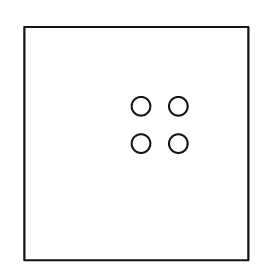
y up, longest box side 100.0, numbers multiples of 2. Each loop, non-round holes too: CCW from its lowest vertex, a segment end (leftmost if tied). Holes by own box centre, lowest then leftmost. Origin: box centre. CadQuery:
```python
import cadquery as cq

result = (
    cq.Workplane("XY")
    .moveTo(-48.0, -50.0)
    .lineTo(48.0, -50.0)
    .lineTo(48.0, 50.0)
    .lineTo(-48.0, 50.0)
    .close()
    .moveTo(2.0, 0.0)
    .circle(4.0)
    .moveTo(18.0, 0.0)
    .circle(4.0)
    .moveTo(2.0, 16.0)
    .circle(4.0)
    .moveTo(18.0, 16.0)
    .circle(4.0)
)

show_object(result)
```